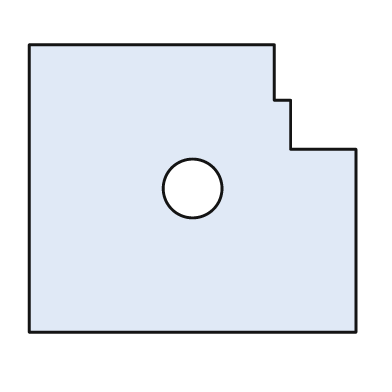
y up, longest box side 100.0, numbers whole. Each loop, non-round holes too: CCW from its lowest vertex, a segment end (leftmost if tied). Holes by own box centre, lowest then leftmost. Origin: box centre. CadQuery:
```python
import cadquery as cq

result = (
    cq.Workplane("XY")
    .moveTo(-50.0, -44.0)
    .lineTo(50.0, -44.0)
    .lineTo(50.0, 12.0)
    .lineTo(30.0, 12.0)
    .lineTo(30.0, 27.0)
    .lineTo(25.0, 27.0)
    .lineTo(25.0, 44.0)
    .lineTo(-50.0, 44.0)
    .close()
    .moveTo(0.0, 0.0)
    .circle(9.0)
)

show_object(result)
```